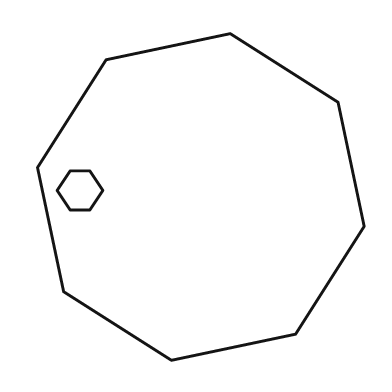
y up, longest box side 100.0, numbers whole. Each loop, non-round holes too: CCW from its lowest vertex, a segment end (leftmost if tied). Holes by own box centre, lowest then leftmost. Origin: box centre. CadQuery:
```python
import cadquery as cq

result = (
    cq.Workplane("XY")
    .moveTo(-9.0, -50.0)
    .lineTo(29.0, -42.0)
    .lineTo(50.0, -9.0)
    .lineTo(42.0, 29.0)
    .lineTo(9.0, 50.0)
    .lineTo(-29.0, 42.0)
    .lineTo(-50.0, 9.0)
    .lineTo(-42.0, -29.0)
    .close()
    .moveTo(-40.0, -4.0)
    .lineTo(-34.0, -4.0)
    .lineTo(-30.0, 2.0)
    .lineTo(-34.0, 8.0)
    .lineTo(-40.0, 8.0)
    .lineTo(-44.0, 2.0)
    .close()
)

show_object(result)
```